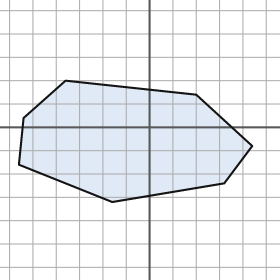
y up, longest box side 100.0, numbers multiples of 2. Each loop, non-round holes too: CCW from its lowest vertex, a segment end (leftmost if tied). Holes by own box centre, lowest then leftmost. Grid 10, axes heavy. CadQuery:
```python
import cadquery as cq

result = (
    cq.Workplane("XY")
    .moveTo(-16.0, -32.0)
    .lineTo(32.0, -24.0)
    .lineTo(44.0, -8.0)
    .lineTo(20.0, 14.0)
    .lineTo(-36.0, 20.0)
    .lineTo(-54.0, 4.0)
    .lineTo(-56.0, -16.0)
    .close()
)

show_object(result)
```